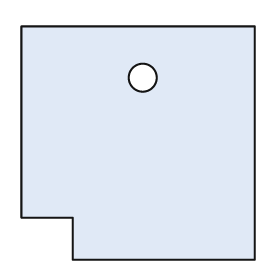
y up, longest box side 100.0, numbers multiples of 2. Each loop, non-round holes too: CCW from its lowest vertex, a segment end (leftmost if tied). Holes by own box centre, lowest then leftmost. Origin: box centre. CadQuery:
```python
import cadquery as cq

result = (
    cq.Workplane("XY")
    .moveTo(-28.0, -50.0)
    .lineTo(50.0, -50.0)
    .lineTo(50.0, 50.0)
    .lineTo(-50.0, 50.0)
    .lineTo(-50.0, -32.0)
    .lineTo(-28.0, -32.0)
    .close()
    .moveTo(2.0, 28.0)
    .circle(6.0)
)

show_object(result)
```